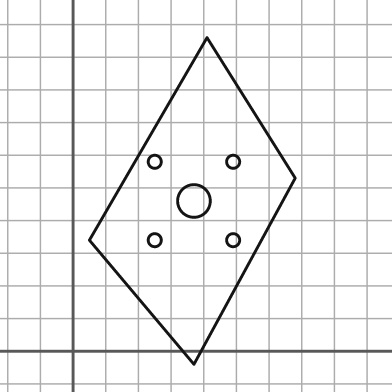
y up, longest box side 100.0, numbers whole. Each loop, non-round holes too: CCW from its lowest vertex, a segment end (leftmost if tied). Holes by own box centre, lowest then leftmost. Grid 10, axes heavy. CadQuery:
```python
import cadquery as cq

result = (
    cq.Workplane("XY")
    .moveTo(37.0, -4.0)
    .lineTo(68.0, 53.0)
    .lineTo(41.0, 96.0)
    .lineTo(5.0, 34.0)
    .close()
    .moveTo(25.0, 34.0)
    .circle(2.0)
    .moveTo(49.0, 34.0)
    .circle(2.0)
    .moveTo(37.0, 46.0)
    .circle(5.0)
    .moveTo(25.0, 58.0)
    .circle(2.0)
    .moveTo(49.0, 58.0)
    .circle(2.0)
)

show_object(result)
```